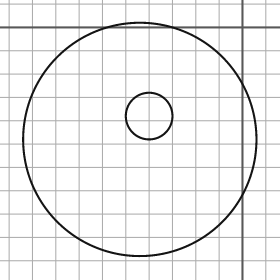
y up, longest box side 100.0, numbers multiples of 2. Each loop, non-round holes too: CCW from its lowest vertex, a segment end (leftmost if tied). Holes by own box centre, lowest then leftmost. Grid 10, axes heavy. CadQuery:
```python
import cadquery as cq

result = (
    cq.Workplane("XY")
    .moveTo(-44.0, -48.0)
    .circle(50.0)
    .moveTo(-40.0, -38.0)
    .circle(10.0)
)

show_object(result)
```